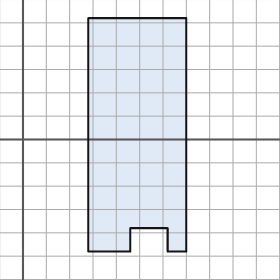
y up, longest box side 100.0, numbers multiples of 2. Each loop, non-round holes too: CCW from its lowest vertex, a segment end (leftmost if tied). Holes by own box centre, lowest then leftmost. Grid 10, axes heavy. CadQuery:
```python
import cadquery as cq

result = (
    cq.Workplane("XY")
    .moveTo(28.0, -48.0)
    .lineTo(46.0, -48.0)
    .lineTo(46.0, -38.0)
    .lineTo(62.0, -38.0)
    .lineTo(62.0, -48.0)
    .lineTo(70.0, -48.0)
    .lineTo(70.0, 52.0)
    .lineTo(28.0, 52.0)
    .close()
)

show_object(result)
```